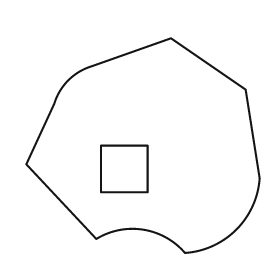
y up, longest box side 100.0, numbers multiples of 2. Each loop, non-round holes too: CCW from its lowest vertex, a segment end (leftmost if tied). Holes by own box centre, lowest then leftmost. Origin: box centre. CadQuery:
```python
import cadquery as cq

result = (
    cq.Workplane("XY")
    .moveTo(18.0, -46.0)
    .threePointArc((40.0, -36.0), (50.0, -14.0))
    .lineTo(44.0, 24.0)
    .lineTo(12.0, 46.0)
    .lineTo(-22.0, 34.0)
    .threePointArc((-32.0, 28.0), (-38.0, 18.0))
    .lineTo(-50.0, -8.0)
    .lineTo(-20.0, -40.0)
    .threePointArc((0.0, -36.0), (18.0, -46.0))
    .close()
    .moveTo(-18.0, -20.0)
    .lineTo(2.0, -20.0)
    .lineTo(2.0, 0.0)
    .lineTo(-18.0, 0.0)
    .close()
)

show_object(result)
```